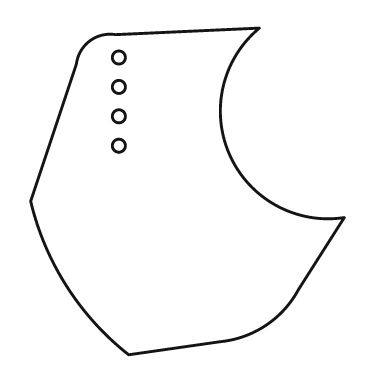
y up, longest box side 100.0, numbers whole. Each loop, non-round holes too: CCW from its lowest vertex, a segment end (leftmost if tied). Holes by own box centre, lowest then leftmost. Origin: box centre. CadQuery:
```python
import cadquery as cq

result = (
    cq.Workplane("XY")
    .moveTo(-18.0, -50.0)
    .lineTo(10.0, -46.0)
    .threePointArc((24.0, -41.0), (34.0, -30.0))
    .lineTo(48.0, -8.0)
    .threePointArc((13.0, 11.0), (22.0, 50.0))
    .lineTo(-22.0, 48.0)
    .threePointArc((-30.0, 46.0), (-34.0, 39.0))
    .lineTo(-48.0, -3.0)
    .threePointArc((-37.0, -29.0), (-18.0, -50.0))
    .close()
    .moveTo(-21.0, 14.0)
    .circle(2.0)
    .moveTo(-21.0, 23.0)
    .circle(2.0)
    .moveTo(-21.0, 32.0)
    .circle(2.0)
    .moveTo(-21.0, 41.0)
    .circle(2.0)
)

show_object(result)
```